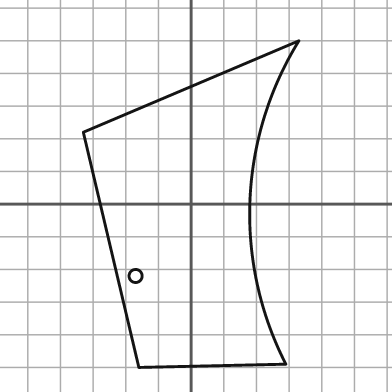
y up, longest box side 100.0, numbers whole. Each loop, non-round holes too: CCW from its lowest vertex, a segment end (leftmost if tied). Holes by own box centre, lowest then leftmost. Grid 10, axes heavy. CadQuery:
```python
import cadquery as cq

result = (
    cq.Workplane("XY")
    .moveTo(-16.0, -50.0)
    .lineTo(29.0, -49.0)
    .threePointArc((18.0, 1.0), (33.0, 50.0))
    .lineTo(-33.0, 22.0)
    .close()
    .moveTo(-17.0, -22.0)
    .circle(2.0)
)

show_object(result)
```